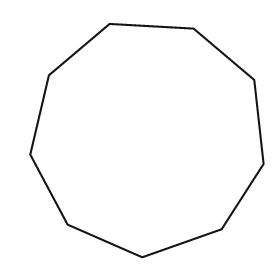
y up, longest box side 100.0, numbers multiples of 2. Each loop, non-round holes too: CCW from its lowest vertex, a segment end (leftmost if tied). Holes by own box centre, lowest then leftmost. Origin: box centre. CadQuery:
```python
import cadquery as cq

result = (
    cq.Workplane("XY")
    .moveTo(-2.0, -50.0)
    .lineTo(32.0, -38.0)
    .lineTo(50.0, -10.0)
    .lineTo(46.0, 26.0)
    .lineTo(20.0, 48.0)
    .lineTo(-16.0, 50.0)
    .lineTo(-42.0, 28.0)
    .lineTo(-50.0, -6.0)
    .lineTo(-34.0, -36.0)
    .close()
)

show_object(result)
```